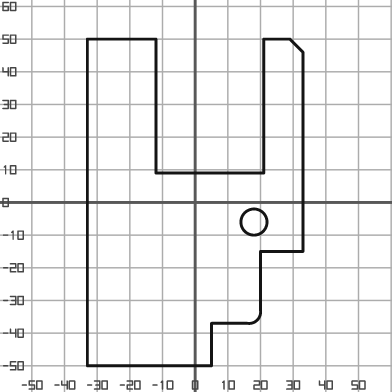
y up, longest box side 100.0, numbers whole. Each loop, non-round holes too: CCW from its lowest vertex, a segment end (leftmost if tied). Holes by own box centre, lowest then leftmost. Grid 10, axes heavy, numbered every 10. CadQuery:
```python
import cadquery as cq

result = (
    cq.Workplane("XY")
    .moveTo(-33.0, -50.0)
    .lineTo(5.0, -50.0)
    .lineTo(5.0, -37.0)
    .lineTo(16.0, -37.0)
    .threePointArc((19.0, -36.0), (20.0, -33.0))
    .lineTo(20.0, -15.0)
    .lineTo(33.0, -15.0)
    .lineTo(33.0, 46.0)
    .lineTo(29.0, 50.0)
    .lineTo(21.0, 50.0)
    .lineTo(21.0, 9.0)
    .lineTo(-12.0, 9.0)
    .lineTo(-12.0, 50.0)
    .lineTo(-33.0, 50.0)
    .close()
    .moveTo(18.0, -6.0)
    .circle(4.0)
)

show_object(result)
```